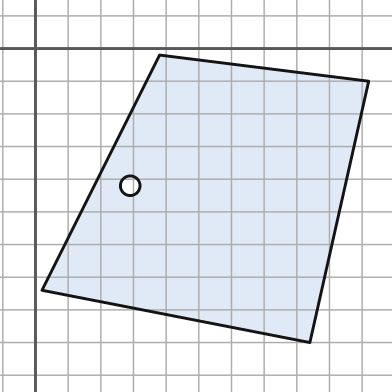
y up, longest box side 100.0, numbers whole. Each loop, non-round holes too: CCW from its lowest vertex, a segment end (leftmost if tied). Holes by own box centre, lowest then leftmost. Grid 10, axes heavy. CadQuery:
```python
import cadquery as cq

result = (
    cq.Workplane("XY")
    .moveTo(84.0, -90.0)
    .lineTo(102.0, -10.0)
    .lineTo(38.0, -2.0)
    .lineTo(2.0, -74.0)
    .close()
    .moveTo(29.0, -42.0)
    .circle(3.0)
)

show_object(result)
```